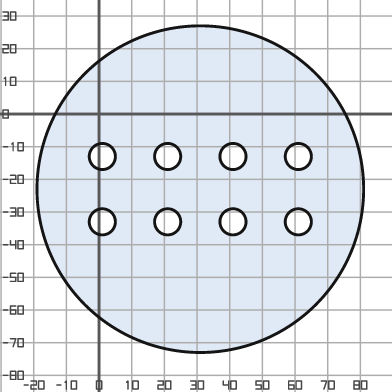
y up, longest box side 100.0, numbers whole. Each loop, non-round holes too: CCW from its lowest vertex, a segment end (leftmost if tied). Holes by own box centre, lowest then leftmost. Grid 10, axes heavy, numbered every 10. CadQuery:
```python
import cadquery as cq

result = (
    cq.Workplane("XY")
    .moveTo(31.0, -23.0)
    .circle(50.0)
    .moveTo(1.0, -33.0)
    .circle(4.0)
    .moveTo(21.0, -33.0)
    .circle(4.0)
    .moveTo(41.0, -33.0)
    .circle(4.0)
    .moveTo(61.0, -33.0)
    .circle(4.0)
    .moveTo(1.0, -13.0)
    .circle(4.0)
    .moveTo(21.0, -13.0)
    .circle(4.0)
    .moveTo(41.0, -13.0)
    .circle(4.0)
    .moveTo(61.0, -13.0)
    .circle(4.0)
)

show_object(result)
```